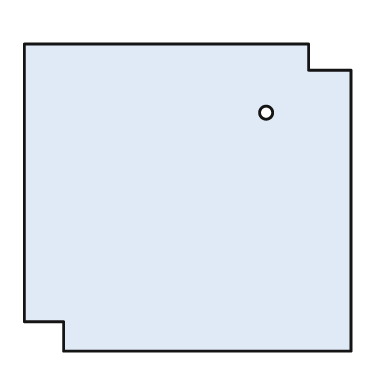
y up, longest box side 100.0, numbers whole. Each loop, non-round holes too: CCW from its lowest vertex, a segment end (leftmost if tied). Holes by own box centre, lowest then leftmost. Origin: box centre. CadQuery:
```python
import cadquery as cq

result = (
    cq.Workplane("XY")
    .moveTo(-38.0, -47.0)
    .lineTo(50.0, -47.0)
    .lineTo(50.0, 39.0)
    .lineTo(37.0, 39.0)
    .lineTo(37.0, 47.0)
    .lineTo(-50.0, 47.0)
    .lineTo(-50.0, -38.0)
    .lineTo(-38.0, -38.0)
    .close()
    .moveTo(24.0, 26.0)
    .circle(2.0)
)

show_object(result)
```